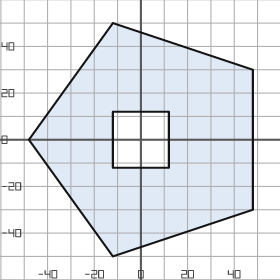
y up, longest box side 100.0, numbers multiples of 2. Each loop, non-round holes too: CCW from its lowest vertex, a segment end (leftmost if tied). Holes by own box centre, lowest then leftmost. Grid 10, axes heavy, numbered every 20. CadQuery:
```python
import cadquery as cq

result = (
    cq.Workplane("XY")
    .moveTo(-12.0, -50.0)
    .lineTo(48.0, -30.0)
    .lineTo(48.0, 30.0)
    .lineTo(-12.0, 50.0)
    .lineTo(-48.0, 0.0)
    .close()
    .moveTo(-12.0, -12.0)
    .lineTo(12.0, -12.0)
    .lineTo(12.0, 12.0)
    .lineTo(-12.0, 12.0)
    .close()
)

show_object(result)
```